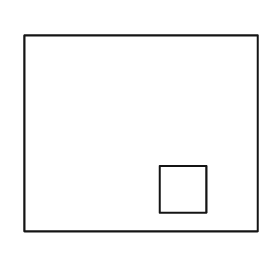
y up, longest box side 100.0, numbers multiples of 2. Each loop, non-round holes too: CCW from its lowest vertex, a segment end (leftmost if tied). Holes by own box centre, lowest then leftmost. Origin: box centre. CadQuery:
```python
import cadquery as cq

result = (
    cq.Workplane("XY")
    .moveTo(-50.0, -42.0)
    .lineTo(50.0, -42.0)
    .lineTo(50.0, 42.0)
    .lineTo(-50.0, 42.0)
    .close()
    .moveTo(8.0, -34.0)
    .lineTo(28.0, -34.0)
    .lineTo(28.0, -14.0)
    .lineTo(8.0, -14.0)
    .close()
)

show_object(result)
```